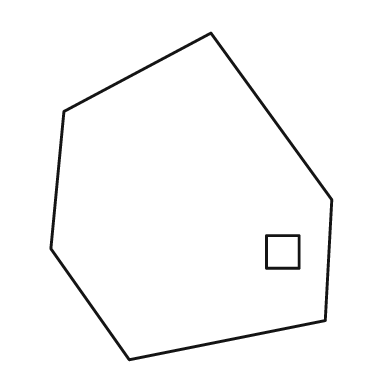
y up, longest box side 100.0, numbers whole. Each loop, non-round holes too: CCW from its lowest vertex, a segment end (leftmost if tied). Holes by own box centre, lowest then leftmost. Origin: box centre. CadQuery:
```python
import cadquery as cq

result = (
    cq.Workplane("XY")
    .moveTo(-19.0, -50.0)
    .lineTo(41.0, -38.0)
    .lineTo(43.0, -1.0)
    .lineTo(6.0, 50.0)
    .lineTo(-39.0, 26.0)
    .lineTo(-43.0, -16.0)
    .close()
    .moveTo(23.0, -22.0)
    .lineTo(33.0, -22.0)
    .lineTo(33.0, -12.0)
    .lineTo(23.0, -12.0)
    .close()
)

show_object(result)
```